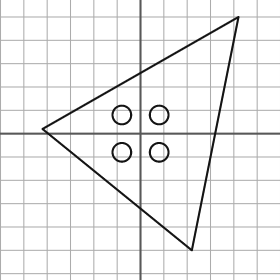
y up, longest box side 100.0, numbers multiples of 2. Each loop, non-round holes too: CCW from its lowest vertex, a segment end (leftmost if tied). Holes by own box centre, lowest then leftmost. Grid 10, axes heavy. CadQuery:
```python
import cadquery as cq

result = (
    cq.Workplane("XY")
    .moveTo(22.0, -50.0)
    .lineTo(42.0, 50.0)
    .lineTo(-42.0, 2.0)
    .close()
    .moveTo(-8.0, -8.0)
    .circle(4.0)
    .moveTo(8.0, -8.0)
    .circle(4.0)
    .moveTo(-8.0, 8.0)
    .circle(4.0)
    .moveTo(8.0, 8.0)
    .circle(4.0)
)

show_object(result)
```